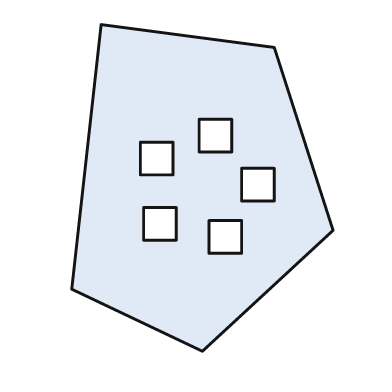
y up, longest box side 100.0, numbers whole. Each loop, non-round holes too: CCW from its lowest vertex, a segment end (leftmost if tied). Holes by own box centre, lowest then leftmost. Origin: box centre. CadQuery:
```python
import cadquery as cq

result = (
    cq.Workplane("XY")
    .moveTo(0.0, -50.0)
    .lineTo(40.0, -13.0)
    .lineTo(22.0, 43.0)
    .lineTo(-31.0, 50.0)
    .lineTo(-40.0, -31.0)
    .close()
    .moveTo(2.0, -20.0)
    .lineTo(12.0, -20.0)
    .lineTo(12.0, -10.0)
    .lineTo(2.0, -10.0)
    .close()
    .moveTo(-18.0, -16.0)
    .lineTo(-8.0, -16.0)
    .lineTo(-8.0, -6.0)
    .lineTo(-18.0, -6.0)
    .close()
    .moveTo(12.0, -4.0)
    .lineTo(22.0, -4.0)
    .lineTo(22.0, 6.0)
    .lineTo(12.0, 6.0)
    .close()
    .moveTo(-19.0, 4.0)
    .lineTo(-9.0, 4.0)
    .lineTo(-9.0, 14.0)
    .lineTo(-19.0, 14.0)
    .close()
    .moveTo(-1.0, 11.0)
    .lineTo(9.0, 11.0)
    .lineTo(9.0, 21.0)
    .lineTo(-1.0, 21.0)
    .close()
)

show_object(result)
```